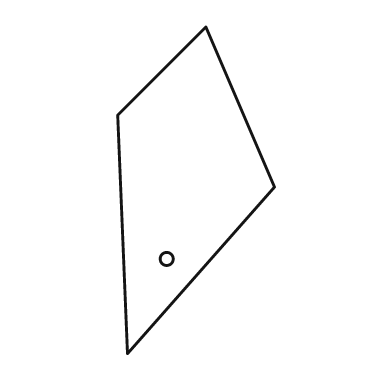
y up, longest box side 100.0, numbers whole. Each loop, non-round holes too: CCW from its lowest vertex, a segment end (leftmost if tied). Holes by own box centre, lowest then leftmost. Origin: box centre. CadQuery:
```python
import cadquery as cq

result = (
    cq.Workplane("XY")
    .moveTo(-21.0, -50.0)
    .lineTo(24.0, 1.0)
    .lineTo(3.0, 50.0)
    .lineTo(-24.0, 23.0)
    .close()
    .moveTo(-9.0, -21.0)
    .circle(2.0)
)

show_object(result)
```